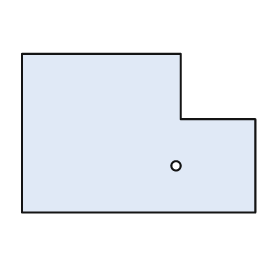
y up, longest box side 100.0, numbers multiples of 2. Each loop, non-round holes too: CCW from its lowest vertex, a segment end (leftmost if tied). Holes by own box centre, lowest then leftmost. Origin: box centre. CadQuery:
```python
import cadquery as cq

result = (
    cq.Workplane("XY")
    .moveTo(-50.0, -34.0)
    .lineTo(50.0, -34.0)
    .lineTo(50.0, 6.0)
    .lineTo(18.0, 6.0)
    .lineTo(18.0, 34.0)
    .lineTo(-50.0, 34.0)
    .close()
    .moveTo(16.0, -14.0)
    .circle(2.0)
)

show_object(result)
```